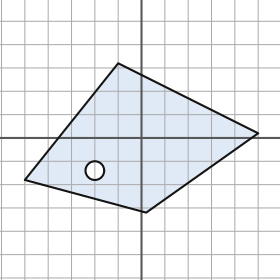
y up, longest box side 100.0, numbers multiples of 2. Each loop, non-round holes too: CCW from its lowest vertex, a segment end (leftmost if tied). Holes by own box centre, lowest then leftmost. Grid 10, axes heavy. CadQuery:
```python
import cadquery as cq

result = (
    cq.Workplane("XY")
    .moveTo(2.0, -32.0)
    .lineTo(50.0, 2.0)
    .lineTo(-10.0, 32.0)
    .lineTo(-50.0, -18.0)
    .close()
    .moveTo(-20.0, -14.0)
    .circle(4.0)
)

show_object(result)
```